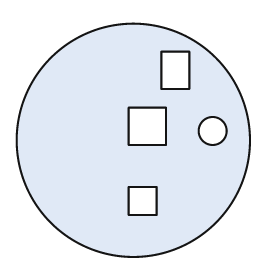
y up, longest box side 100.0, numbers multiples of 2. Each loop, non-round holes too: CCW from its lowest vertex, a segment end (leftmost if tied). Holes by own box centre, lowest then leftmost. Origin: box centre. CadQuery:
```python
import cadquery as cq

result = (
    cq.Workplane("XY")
    .moveTo(0.0, 0.0)
    .circle(50.0)
    .moveTo(-2.0, -32.0)
    .lineTo(10.0, -32.0)
    .lineTo(10.0, -20.0)
    .lineTo(-2.0, -20.0)
    .close()
    .moveTo(34.0, 4.0)
    .circle(6.0)
    .moveTo(-2.0, -2.0)
    .lineTo(14.0, -2.0)
    .lineTo(14.0, 14.0)
    .lineTo(-2.0, 14.0)
    .close()
    .moveTo(12.0, 22.0)
    .lineTo(24.0, 22.0)
    .lineTo(24.0, 38.0)
    .lineTo(12.0, 38.0)
    .close()
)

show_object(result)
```